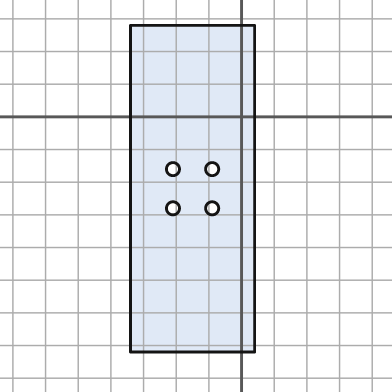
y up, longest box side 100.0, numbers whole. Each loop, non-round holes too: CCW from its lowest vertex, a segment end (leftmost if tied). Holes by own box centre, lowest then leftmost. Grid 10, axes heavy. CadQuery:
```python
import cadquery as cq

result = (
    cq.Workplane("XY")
    .moveTo(-34.0, -72.0)
    .lineTo(4.0, -72.0)
    .lineTo(4.0, 28.0)
    .lineTo(-34.0, 28.0)
    .close()
    .moveTo(-21.0, -28.0)
    .circle(2.0)
    .moveTo(-9.0, -28.0)
    .circle(2.0)
    .moveTo(-21.0, -16.0)
    .circle(2.0)
    .moveTo(-9.0, -16.0)
    .circle(2.0)
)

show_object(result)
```